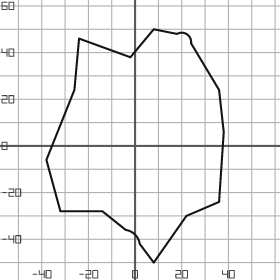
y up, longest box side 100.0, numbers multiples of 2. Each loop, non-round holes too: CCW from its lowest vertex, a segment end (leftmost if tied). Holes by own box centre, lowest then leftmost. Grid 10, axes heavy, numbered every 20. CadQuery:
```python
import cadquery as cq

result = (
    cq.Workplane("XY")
    .moveTo(8.0, -50.0)
    .lineTo(22.0, -30.0)
    .lineTo(36.0, -24.0)
    .lineTo(38.0, 6.0)
    .lineTo(36.0, 24.0)
    .lineTo(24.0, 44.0)
    .threePointArc((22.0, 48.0), (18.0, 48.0))
    .lineTo(8.0, 50.0)
    .lineTo(-2.0, 38.0)
    .lineTo(-24.0, 46.0)
    .lineTo(-26.0, 24.0)
    .lineTo(-38.0, -6.0)
    .lineTo(-32.0, -28.0)
    .lineTo(-14.0, -28.0)
    .lineTo(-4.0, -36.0)
    .threePointArc((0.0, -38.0), (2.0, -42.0))
    .close()
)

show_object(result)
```